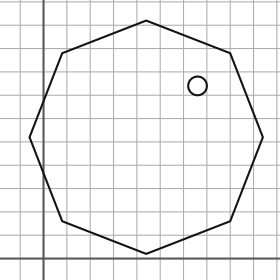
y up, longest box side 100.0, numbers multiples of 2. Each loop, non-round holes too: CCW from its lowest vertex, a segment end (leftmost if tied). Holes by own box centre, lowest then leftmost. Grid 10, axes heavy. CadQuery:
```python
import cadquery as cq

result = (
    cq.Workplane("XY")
    .moveTo(44.0, 2.0)
    .lineTo(80.0, 16.0)
    .lineTo(94.0, 52.0)
    .lineTo(80.0, 88.0)
    .lineTo(44.0, 102.0)
    .lineTo(8.0, 88.0)
    .lineTo(-6.0, 52.0)
    .lineTo(8.0, 16.0)
    .close()
    .moveTo(66.0, 74.0)
    .circle(4.0)
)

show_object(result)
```